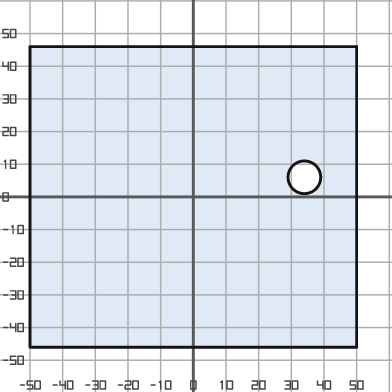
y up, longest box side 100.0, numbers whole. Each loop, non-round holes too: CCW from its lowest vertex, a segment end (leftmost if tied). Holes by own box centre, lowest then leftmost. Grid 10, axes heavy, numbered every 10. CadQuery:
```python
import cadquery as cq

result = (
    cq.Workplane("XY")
    .moveTo(-50.0, -46.0)
    .lineTo(50.0, -46.0)
    .lineTo(50.0, 46.0)
    .lineTo(-50.0, 46.0)
    .close()
    .moveTo(34.0, 6.0)
    .circle(5.0)
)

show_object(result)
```